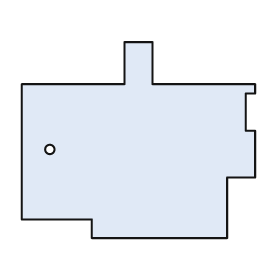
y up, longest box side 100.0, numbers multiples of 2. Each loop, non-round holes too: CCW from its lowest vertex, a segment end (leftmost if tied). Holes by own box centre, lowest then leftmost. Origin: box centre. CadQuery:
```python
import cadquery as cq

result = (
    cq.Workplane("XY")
    .moveTo(-20.0, -42.0)
    .lineTo(38.0, -42.0)
    .lineTo(38.0, -16.0)
    .lineTo(50.0, -16.0)
    .lineTo(50.0, 4.0)
    .lineTo(46.0, 4.0)
    .lineTo(46.0, 20.0)
    .lineTo(50.0, 20.0)
    .lineTo(50.0, 24.0)
    .lineTo(6.0, 24.0)
    .lineTo(6.0, 42.0)
    .lineTo(-6.0, 42.0)
    .lineTo(-6.0, 24.0)
    .lineTo(-50.0, 24.0)
    .lineTo(-50.0, -34.0)
    .lineTo(-20.0, -34.0)
    .close()
    .moveTo(-38.0, -4.0)
    .circle(2.0)
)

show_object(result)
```